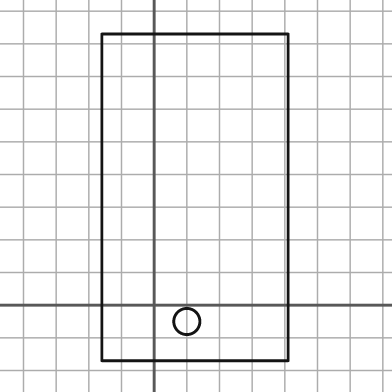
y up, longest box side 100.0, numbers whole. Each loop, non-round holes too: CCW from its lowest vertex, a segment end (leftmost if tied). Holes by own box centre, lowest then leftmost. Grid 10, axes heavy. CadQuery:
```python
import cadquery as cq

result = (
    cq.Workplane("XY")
    .moveTo(-16.0, -17.0)
    .lineTo(41.0, -17.0)
    .lineTo(41.0, 83.0)
    .lineTo(-16.0, 83.0)
    .close()
    .moveTo(10.0, -5.0)
    .circle(4.0)
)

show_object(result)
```